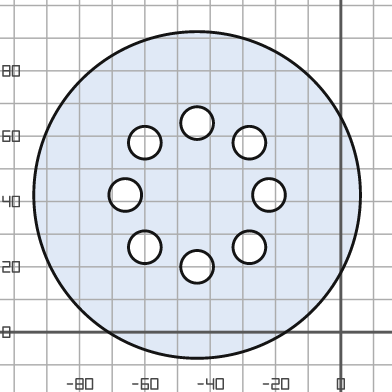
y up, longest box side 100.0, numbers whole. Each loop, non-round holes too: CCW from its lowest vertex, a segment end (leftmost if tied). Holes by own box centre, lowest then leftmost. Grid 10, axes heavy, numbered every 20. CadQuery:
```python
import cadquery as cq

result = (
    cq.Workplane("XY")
    .moveTo(-44.0, 42.0)
    .circle(50.0)
    .moveTo(-44.0, 20.0)
    .circle(5.0)
    .moveTo(-60.0, 26.0)
    .circle(5.0)
    .moveTo(-28.0, 26.0)
    .circle(5.0)
    .moveTo(-66.0, 42.0)
    .circle(5.0)
    .moveTo(-22.0, 42.0)
    .circle(5.0)
    .moveTo(-60.0, 58.0)
    .circle(5.0)
    .moveTo(-28.0, 58.0)
    .circle(5.0)
    .moveTo(-44.0, 64.0)
    .circle(5.0)
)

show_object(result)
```